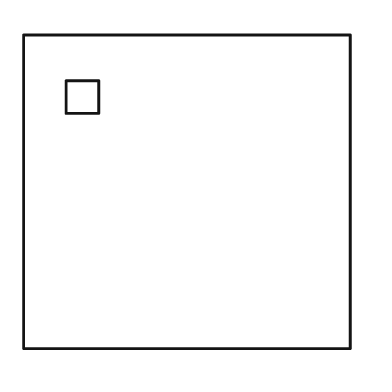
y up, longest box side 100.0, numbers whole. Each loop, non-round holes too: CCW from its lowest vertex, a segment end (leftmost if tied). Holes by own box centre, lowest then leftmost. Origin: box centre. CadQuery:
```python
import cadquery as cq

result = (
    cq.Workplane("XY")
    .moveTo(-50.0, -48.0)
    .lineTo(50.0, -48.0)
    .lineTo(50.0, 48.0)
    .lineTo(-50.0, 48.0)
    .close()
    .moveTo(-37.0, 24.0)
    .lineTo(-27.0, 24.0)
    .lineTo(-27.0, 34.0)
    .lineTo(-37.0, 34.0)
    .close()
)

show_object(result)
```